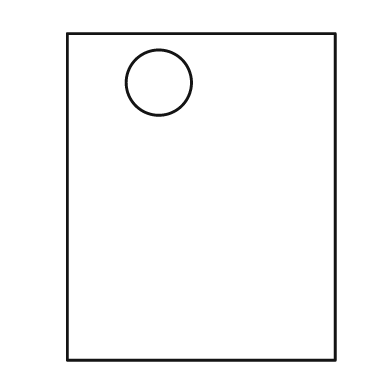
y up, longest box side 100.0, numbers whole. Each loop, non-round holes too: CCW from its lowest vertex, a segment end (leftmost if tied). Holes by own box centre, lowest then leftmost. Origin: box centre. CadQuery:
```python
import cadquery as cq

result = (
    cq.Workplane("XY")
    .moveTo(-41.0, -50.0)
    .lineTo(41.0, -50.0)
    .lineTo(41.0, 50.0)
    .lineTo(-41.0, 50.0)
    .close()
    .moveTo(-13.0, 35.0)
    .circle(10.0)
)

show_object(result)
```